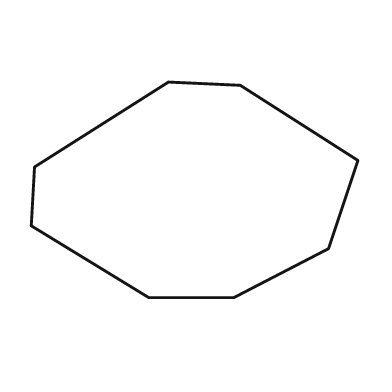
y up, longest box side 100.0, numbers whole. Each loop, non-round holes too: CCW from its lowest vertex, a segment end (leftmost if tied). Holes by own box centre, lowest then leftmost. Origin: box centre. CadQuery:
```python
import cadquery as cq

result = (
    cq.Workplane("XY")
    .moveTo(-14.0, -33.0)
    .lineTo(12.0, -33.0)
    .lineTo(41.0, -18.0)
    .lineTo(50.0, 9.0)
    .lineTo(14.0, 32.0)
    .lineTo(-8.0, 33.0)
    .lineTo(-49.0, 7.0)
    .lineTo(-50.0, -11.0)
    .close()
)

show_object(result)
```